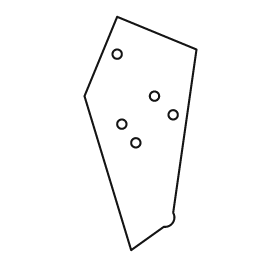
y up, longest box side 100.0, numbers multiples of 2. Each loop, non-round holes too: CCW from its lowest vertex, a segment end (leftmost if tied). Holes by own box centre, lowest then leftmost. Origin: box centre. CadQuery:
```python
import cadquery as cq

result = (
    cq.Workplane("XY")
    .moveTo(-4.0, -50.0)
    .lineTo(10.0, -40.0)
    .threePointArc((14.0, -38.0), (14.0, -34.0))
    .lineTo(24.0, 36.0)
    .lineTo(-10.0, 50.0)
    .lineTo(-24.0, 16.0)
    .close()
    .moveTo(-2.0, -4.0)
    .circle(2.0)
    .moveTo(-8.0, 4.0)
    .circle(2.0)
    .moveTo(14.0, 8.0)
    .circle(2.0)
    .moveTo(6.0, 16.0)
    .circle(2.0)
    .moveTo(-10.0, 34.0)
    .circle(2.0)
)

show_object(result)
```